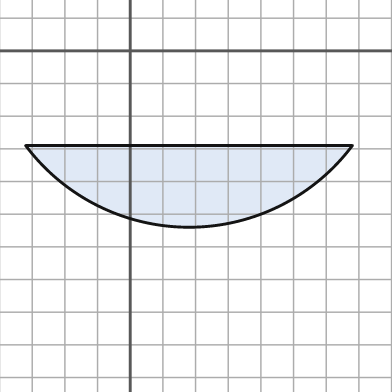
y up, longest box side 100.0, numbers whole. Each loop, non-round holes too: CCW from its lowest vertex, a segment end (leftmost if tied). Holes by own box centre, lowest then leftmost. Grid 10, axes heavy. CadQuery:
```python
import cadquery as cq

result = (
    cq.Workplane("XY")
    .moveTo(-32.0, -29.0)
    .threePointArc((18.0, -54.0), (68.0, -29.0))
    .close()
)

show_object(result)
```